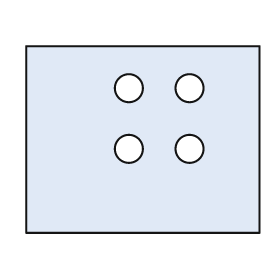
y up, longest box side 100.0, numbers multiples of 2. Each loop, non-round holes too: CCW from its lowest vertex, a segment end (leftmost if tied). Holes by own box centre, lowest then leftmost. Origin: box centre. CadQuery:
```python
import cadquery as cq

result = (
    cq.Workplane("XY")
    .moveTo(-50.0, -40.0)
    .lineTo(50.0, -40.0)
    .lineTo(50.0, 40.0)
    .lineTo(-50.0, 40.0)
    .close()
    .moveTo(-6.0, -4.0)
    .circle(6.0)
    .moveTo(20.0, -4.0)
    .circle(6.0)
    .moveTo(-6.0, 22.0)
    .circle(6.0)
    .moveTo(20.0, 22.0)
    .circle(6.0)
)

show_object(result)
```